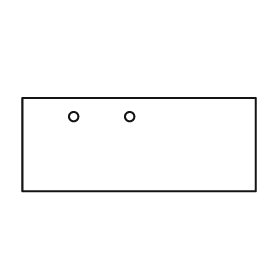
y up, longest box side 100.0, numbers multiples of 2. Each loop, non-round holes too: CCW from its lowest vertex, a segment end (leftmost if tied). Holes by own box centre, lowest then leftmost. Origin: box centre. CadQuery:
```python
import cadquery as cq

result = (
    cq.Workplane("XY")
    .moveTo(-50.0, -20.0)
    .lineTo(50.0, -20.0)
    .lineTo(50.0, 20.0)
    .lineTo(-50.0, 20.0)
    .close()
    .moveTo(-28.0, 12.0)
    .circle(2.0)
    .moveTo(-4.0, 12.0)
    .circle(2.0)
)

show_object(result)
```